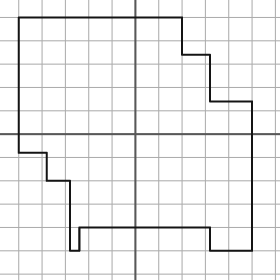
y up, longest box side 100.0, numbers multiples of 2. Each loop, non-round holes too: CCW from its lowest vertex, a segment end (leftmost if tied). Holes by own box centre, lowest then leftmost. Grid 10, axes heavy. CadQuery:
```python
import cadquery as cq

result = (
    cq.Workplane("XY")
    .moveTo(-28.0, -50.0)
    .lineTo(-24.0, -50.0)
    .lineTo(-24.0, -40.0)
    .lineTo(32.0, -40.0)
    .lineTo(32.0, -50.0)
    .lineTo(50.0, -50.0)
    .lineTo(50.0, 14.0)
    .lineTo(32.0, 14.0)
    .lineTo(32.0, 34.0)
    .lineTo(20.0, 34.0)
    .lineTo(20.0, 50.0)
    .lineTo(-50.0, 50.0)
    .lineTo(-50.0, -8.0)
    .lineTo(-38.0, -8.0)
    .lineTo(-38.0, -20.0)
    .lineTo(-28.0, -20.0)
    .close()
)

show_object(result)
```